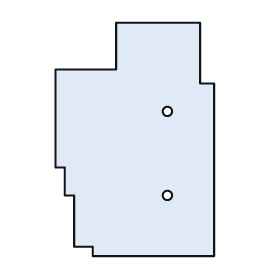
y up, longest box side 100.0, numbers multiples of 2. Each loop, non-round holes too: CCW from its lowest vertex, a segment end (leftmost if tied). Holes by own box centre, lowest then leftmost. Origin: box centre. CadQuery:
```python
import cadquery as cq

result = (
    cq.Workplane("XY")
    .moveTo(-18.0, -50.0)
    .lineTo(34.0, -50.0)
    .lineTo(34.0, 24.0)
    .lineTo(28.0, 24.0)
    .lineTo(28.0, 50.0)
    .lineTo(-8.0, 50.0)
    .lineTo(-8.0, 30.0)
    .lineTo(-34.0, 30.0)
    .lineTo(-34.0, -12.0)
    .lineTo(-30.0, -12.0)
    .lineTo(-30.0, -24.0)
    .lineTo(-26.0, -24.0)
    .lineTo(-26.0, -46.0)
    .lineTo(-18.0, -46.0)
    .close()
    .moveTo(14.0, -24.0)
    .circle(2.0)
    .moveTo(14.0, 12.0)
    .circle(2.0)
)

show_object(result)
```